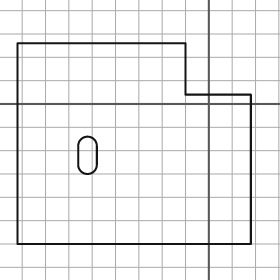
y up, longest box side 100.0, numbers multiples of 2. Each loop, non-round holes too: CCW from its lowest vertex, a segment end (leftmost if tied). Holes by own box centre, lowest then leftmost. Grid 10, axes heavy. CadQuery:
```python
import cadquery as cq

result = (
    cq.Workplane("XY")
    .moveTo(-82.0, -60.0)
    .lineTo(18.0, -60.0)
    .lineTo(18.0, 4.0)
    .lineTo(-10.0, 4.0)
    .lineTo(-10.0, 26.0)
    .lineTo(-82.0, 26.0)
    .close()
    .moveTo(-56.0, -26.0)
    .threePointArc((-52.0, -30.0), (-48.0, -26.0))
    .lineTo(-48.0, -18.0)
    .threePointArc((-52.0, -14.0), (-56.0, -18.0))
    .close()
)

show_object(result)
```